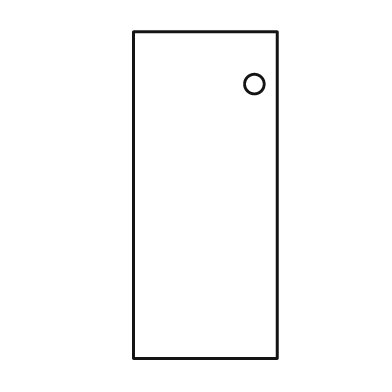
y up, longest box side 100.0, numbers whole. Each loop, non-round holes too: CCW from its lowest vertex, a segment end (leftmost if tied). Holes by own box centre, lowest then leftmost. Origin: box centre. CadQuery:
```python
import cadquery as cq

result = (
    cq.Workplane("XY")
    .moveTo(-22.0, -50.0)
    .lineTo(22.0, -50.0)
    .lineTo(22.0, 50.0)
    .lineTo(-22.0, 50.0)
    .close()
    .moveTo(15.0, 34.0)
    .circle(3.0)
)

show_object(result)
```